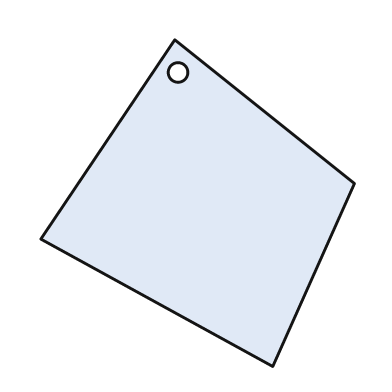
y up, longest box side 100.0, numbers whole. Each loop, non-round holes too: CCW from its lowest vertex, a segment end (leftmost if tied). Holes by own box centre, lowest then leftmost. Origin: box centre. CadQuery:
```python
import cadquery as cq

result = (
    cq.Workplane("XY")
    .moveTo(23.0, -50.0)
    .lineTo(48.0, 6.0)
    .lineTo(-7.0, 50.0)
    .lineTo(-48.0, -11.0)
    .close()
    .moveTo(-6.0, 40.0)
    .circle(3.0)
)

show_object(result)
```